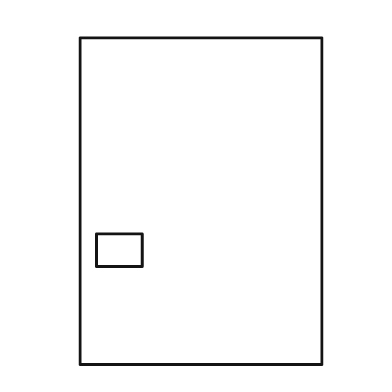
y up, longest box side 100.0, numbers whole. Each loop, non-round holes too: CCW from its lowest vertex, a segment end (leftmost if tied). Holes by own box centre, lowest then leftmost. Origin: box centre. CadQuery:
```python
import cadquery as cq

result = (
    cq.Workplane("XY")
    .moveTo(-37.0, -50.0)
    .lineTo(37.0, -50.0)
    .lineTo(37.0, 50.0)
    .lineTo(-37.0, 50.0)
    .close()
    .moveTo(-32.0, -20.0)
    .lineTo(-18.0, -20.0)
    .lineTo(-18.0, -10.0)
    .lineTo(-32.0, -10.0)
    .close()
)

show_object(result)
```